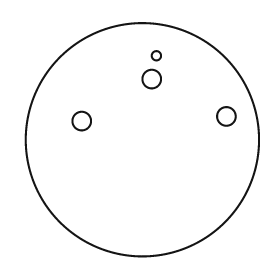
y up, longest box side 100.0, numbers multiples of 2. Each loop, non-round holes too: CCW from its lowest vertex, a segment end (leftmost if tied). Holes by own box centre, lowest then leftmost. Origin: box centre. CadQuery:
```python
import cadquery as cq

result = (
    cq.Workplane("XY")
    .moveTo(0.0, 0.0)
    .circle(50.0)
    .moveTo(-26.0, 8.0)
    .circle(4.0)
    .moveTo(36.0, 10.0)
    .circle(4.0)
    .moveTo(4.0, 26.0)
    .circle(4.0)
    .moveTo(6.0, 36.0)
    .circle(2.0)
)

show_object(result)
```